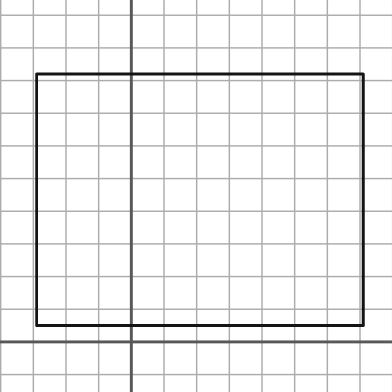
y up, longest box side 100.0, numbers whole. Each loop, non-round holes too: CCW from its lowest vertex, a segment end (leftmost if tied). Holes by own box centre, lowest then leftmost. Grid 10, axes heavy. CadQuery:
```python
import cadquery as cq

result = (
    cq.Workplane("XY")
    .moveTo(-29.0, 5.0)
    .lineTo(71.0, 5.0)
    .lineTo(71.0, 82.0)
    .lineTo(-29.0, 82.0)
    .close()
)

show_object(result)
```